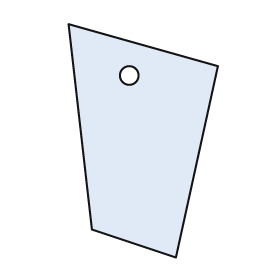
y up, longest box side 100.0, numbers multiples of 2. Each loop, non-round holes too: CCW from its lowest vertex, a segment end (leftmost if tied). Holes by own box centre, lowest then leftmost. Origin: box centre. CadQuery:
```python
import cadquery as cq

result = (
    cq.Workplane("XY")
    .moveTo(14.0, -50.0)
    .lineTo(32.0, 32.0)
    .lineTo(-32.0, 50.0)
    .lineTo(-22.0, -38.0)
    .close()
    .moveTo(-6.0, 28.0)
    .circle(4.0)
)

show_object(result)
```